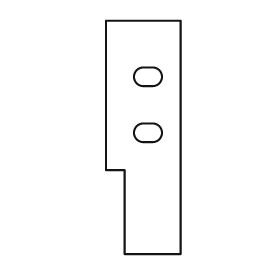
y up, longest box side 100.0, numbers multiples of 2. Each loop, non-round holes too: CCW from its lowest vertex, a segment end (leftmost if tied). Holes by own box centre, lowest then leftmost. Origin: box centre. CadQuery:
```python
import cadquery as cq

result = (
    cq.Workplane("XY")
    .moveTo(-8.0, -50.0)
    .lineTo(16.0, -50.0)
    .lineTo(16.0, 50.0)
    .lineTo(-16.0, 50.0)
    .lineTo(-16.0, -14.0)
    .lineTo(-8.0, -14.0)
    .close()
    .moveTo(0.0, -2.0)
    .lineTo(4.0, -2.0)
    .threePointArc((8.0, 2.0), (4.0, 6.0))
    .lineTo(0.0, 6.0)
    .threePointArc((-4.0, 2.0), (0.0, -2.0))
    .close()
    .moveTo(0.0, 22.0)
    .lineTo(4.0, 22.0)
    .threePointArc((8.0, 26.0), (4.0, 30.0))
    .lineTo(0.0, 30.0)
    .threePointArc((-4.0, 26.0), (0.0, 22.0))
    .close()
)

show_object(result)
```